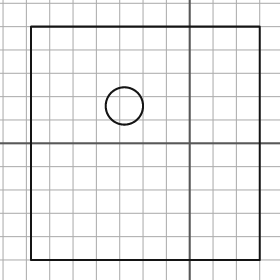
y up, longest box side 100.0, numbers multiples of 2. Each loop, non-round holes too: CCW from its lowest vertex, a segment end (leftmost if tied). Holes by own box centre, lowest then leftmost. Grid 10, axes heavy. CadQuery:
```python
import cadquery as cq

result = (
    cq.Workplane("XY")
    .moveTo(-68.0, -50.0)
    .lineTo(30.0, -50.0)
    .lineTo(30.0, 50.0)
    .lineTo(-68.0, 50.0)
    .close()
    .moveTo(-28.0, 16.0)
    .circle(8.0)
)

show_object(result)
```